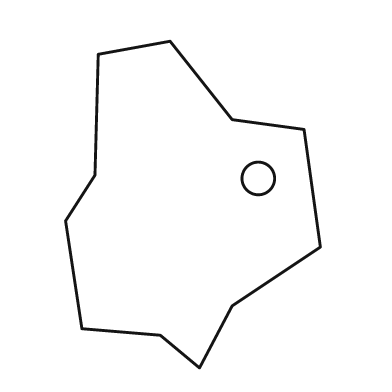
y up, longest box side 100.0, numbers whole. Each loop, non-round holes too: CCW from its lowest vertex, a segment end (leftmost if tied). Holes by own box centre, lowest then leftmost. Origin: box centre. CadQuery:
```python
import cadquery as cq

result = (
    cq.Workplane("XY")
    .moveTo(2.0, -50.0)
    .lineTo(12.0, -31.0)
    .lineTo(39.0, -13.0)
    .lineTo(34.0, 23.0)
    .lineTo(12.0, 26.0)
    .lineTo(-7.0, 50.0)
    .lineTo(-29.0, 46.0)
    .lineTo(-30.0, 9.0)
    .lineTo(-39.0, -5.0)
    .lineTo(-34.0, -38.0)
    .lineTo(-10.0, -40.0)
    .close()
    .moveTo(20.0, 8.0)
    .circle(5.0)
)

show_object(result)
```